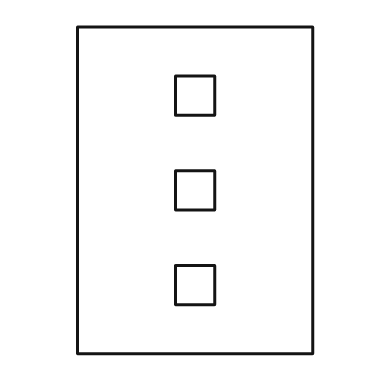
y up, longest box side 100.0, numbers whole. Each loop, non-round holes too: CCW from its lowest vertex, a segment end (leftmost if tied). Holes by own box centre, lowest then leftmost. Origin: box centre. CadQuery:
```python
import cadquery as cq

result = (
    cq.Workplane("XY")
    .moveTo(-36.0, -50.0)
    .lineTo(36.0, -50.0)
    .lineTo(36.0, 50.0)
    .lineTo(-36.0, 50.0)
    .close()
    .moveTo(-6.0, -35.0)
    .lineTo(6.0, -35.0)
    .lineTo(6.0, -23.0)
    .lineTo(-6.0, -23.0)
    .close()
    .moveTo(-6.0, -6.0)
    .lineTo(6.0, -6.0)
    .lineTo(6.0, 6.0)
    .lineTo(-6.0, 6.0)
    .close()
    .moveTo(-6.0, 23.0)
    .lineTo(6.0, 23.0)
    .lineTo(6.0, 35.0)
    .lineTo(-6.0, 35.0)
    .close()
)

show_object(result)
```